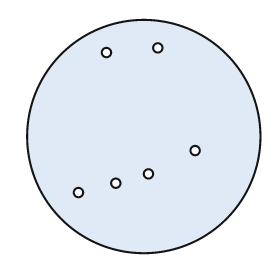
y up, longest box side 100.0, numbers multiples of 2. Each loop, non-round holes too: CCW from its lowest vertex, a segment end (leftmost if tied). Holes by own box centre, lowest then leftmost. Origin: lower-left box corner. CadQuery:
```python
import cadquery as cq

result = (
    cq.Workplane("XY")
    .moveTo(50.0, 50.0)
    .circle(50.0)
    .moveTo(22.0, 26.0)
    .circle(2.0)
    .moveTo(38.0, 30.0)
    .circle(2.0)
    .moveTo(52.0, 34.0)
    .circle(2.0)
    .moveTo(72.0, 44.0)
    .circle(2.0)
    .moveTo(34.0, 86.0)
    .circle(2.0)
    .moveTo(56.0, 88.0)
    .circle(2.0)
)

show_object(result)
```